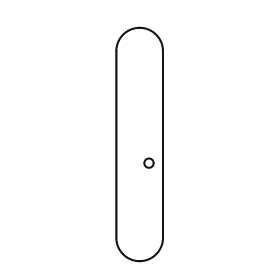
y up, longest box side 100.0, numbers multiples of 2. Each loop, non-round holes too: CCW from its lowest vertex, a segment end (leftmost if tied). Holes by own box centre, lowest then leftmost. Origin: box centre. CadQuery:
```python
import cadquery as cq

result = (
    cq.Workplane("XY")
    .moveTo(-10.0, -40.0)
    .threePointArc((0.0, -50.0), (10.0, -40.0))
    .lineTo(10.0, 40.0)
    .threePointArc((0.0, 50.0), (-10.0, 40.0))
    .close()
    .moveTo(4.0, -8.0)
    .circle(2.0)
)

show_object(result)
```